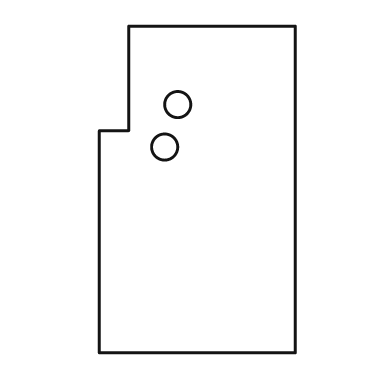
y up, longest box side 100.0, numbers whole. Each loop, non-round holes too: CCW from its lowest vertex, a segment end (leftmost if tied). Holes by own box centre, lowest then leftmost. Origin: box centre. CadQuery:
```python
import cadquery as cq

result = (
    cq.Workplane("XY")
    .moveTo(-30.0, -50.0)
    .lineTo(30.0, -50.0)
    .lineTo(30.0, 50.0)
    .lineTo(-21.0, 50.0)
    .lineTo(-21.0, 18.0)
    .lineTo(-30.0, 18.0)
    .close()
    .moveTo(-10.0, 13.0)
    .circle(4.0)
    .moveTo(-6.0, 26.0)
    .circle(4.0)
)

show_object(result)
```